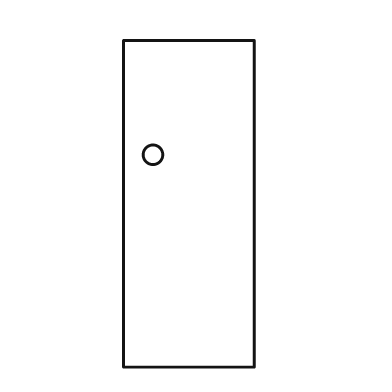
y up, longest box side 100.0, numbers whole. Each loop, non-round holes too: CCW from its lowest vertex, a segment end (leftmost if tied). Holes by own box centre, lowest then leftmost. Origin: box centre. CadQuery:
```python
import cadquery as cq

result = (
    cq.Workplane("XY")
    .moveTo(-20.0, -50.0)
    .lineTo(20.0, -50.0)
    .lineTo(20.0, 50.0)
    .lineTo(-20.0, 50.0)
    .close()
    .moveTo(-11.0, 15.0)
    .circle(3.0)
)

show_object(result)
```